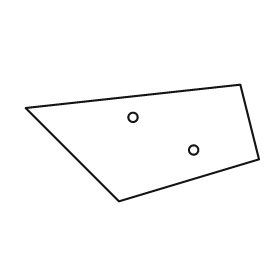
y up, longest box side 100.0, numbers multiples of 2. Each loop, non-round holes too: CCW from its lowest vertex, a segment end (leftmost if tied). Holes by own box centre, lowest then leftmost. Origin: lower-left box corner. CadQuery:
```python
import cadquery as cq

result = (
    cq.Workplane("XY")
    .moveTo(40.0, 0.0)
    .lineTo(100.0, 18.0)
    .lineTo(92.0, 50.0)
    .lineTo(0.0, 40.0)
    .close()
    .moveTo(72.0, 22.0)
    .circle(2.0)
    .moveTo(46.0, 36.0)
    .circle(2.0)
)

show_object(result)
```